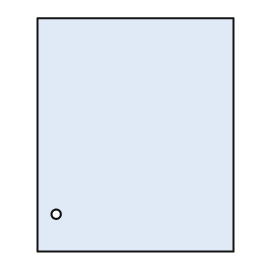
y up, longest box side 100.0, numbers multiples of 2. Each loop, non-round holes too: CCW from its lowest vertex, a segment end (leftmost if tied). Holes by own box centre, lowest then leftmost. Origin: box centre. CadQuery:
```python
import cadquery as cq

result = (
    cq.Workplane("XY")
    .moveTo(-42.0, -50.0)
    .lineTo(42.0, -50.0)
    .lineTo(42.0, 50.0)
    .lineTo(-42.0, 50.0)
    .close()
    .moveTo(-34.0, -34.0)
    .circle(2.0)
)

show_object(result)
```